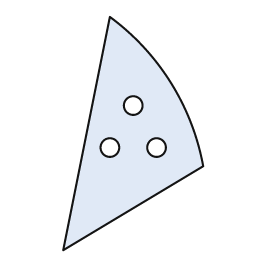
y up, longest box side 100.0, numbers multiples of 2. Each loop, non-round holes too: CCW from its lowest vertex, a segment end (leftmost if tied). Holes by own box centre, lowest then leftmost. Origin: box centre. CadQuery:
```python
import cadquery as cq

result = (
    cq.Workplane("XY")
    .moveTo(-30.0, -50.0)
    .lineTo(30.0, -14.0)
    .threePointArc((16.0, 22.0), (-10.0, 50.0))
    .close()
    .moveTo(-10.0, -6.0)
    .circle(4.0)
    .moveTo(10.0, -6.0)
    .circle(4.0)
    .moveTo(0.0, 12.0)
    .circle(4.0)
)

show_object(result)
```